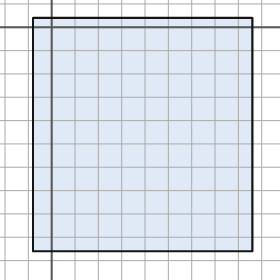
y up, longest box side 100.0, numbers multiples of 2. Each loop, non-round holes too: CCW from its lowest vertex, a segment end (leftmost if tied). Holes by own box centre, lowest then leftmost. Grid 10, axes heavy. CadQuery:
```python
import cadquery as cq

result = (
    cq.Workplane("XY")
    .moveTo(-8.0, -96.0)
    .lineTo(86.0, -96.0)
    .lineTo(86.0, 4.0)
    .lineTo(-8.0, 4.0)
    .close()
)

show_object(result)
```